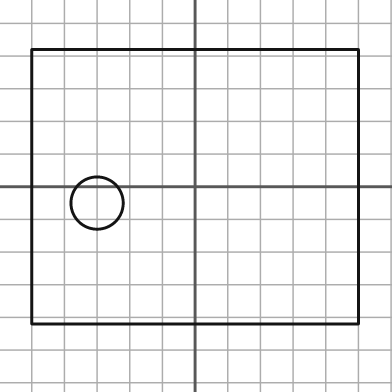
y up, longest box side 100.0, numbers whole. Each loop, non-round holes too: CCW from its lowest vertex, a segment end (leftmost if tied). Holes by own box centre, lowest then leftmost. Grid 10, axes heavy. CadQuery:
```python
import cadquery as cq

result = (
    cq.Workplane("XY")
    .moveTo(-50.0, -42.0)
    .lineTo(50.0, -42.0)
    .lineTo(50.0, 42.0)
    .lineTo(-50.0, 42.0)
    .close()
    .moveTo(-30.0, -5.0)
    .circle(8.0)
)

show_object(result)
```